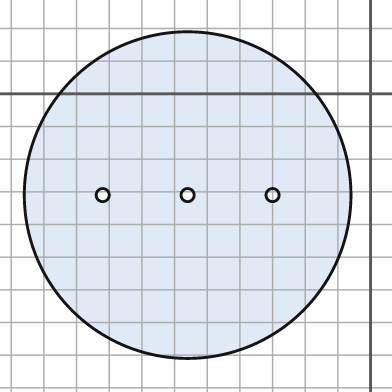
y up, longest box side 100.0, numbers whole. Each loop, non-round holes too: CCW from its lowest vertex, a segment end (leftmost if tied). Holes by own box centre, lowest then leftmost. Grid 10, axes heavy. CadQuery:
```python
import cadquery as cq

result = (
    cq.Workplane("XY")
    .moveTo(-56.0, -31.0)
    .circle(50.0)
    .moveTo(-82.0, -31.0)
    .circle(2.0)
    .moveTo(-56.0, -31.0)
    .circle(2.0)
    .moveTo(-30.0, -31.0)
    .circle(2.0)
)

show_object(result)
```